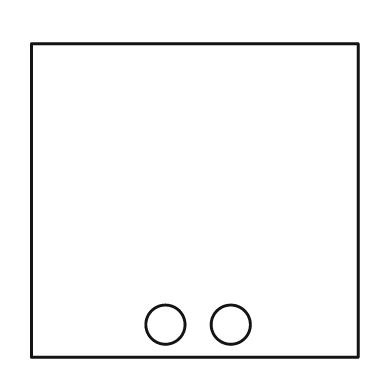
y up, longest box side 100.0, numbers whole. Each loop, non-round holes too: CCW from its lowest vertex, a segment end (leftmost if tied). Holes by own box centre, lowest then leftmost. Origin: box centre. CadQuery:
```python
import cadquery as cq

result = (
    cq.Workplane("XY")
    .moveTo(-50.0, -48.0)
    .lineTo(50.0, -48.0)
    .lineTo(50.0, 48.0)
    .lineTo(-50.0, 48.0)
    .close()
    .moveTo(-9.0, -38.0)
    .circle(6.0)
    .moveTo(11.0, -38.0)
    .circle(6.0)
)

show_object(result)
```